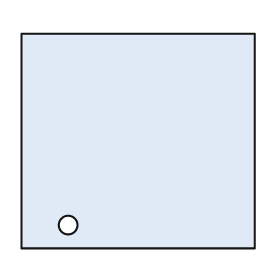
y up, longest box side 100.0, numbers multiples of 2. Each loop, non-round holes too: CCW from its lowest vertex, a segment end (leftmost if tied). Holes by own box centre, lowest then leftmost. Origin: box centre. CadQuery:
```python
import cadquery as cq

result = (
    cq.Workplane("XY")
    .moveTo(-50.0, -46.0)
    .lineTo(50.0, -46.0)
    .lineTo(50.0, 46.0)
    .lineTo(-50.0, 46.0)
    .close()
    .moveTo(-30.0, -36.0)
    .circle(4.0)
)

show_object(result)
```